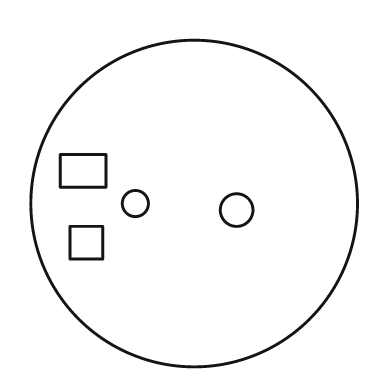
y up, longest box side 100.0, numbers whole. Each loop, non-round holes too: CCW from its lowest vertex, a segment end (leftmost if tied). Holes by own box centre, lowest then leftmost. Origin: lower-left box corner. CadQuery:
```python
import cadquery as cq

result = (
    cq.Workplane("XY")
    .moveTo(50.0, 50.0)
    .circle(50.0)
    .moveTo(12.0, 33.0)
    .lineTo(22.0, 33.0)
    .lineTo(22.0, 43.0)
    .lineTo(12.0, 43.0)
    .close()
    .moveTo(63.0, 48.0)
    .circle(5.0)
    .moveTo(32.0, 50.0)
    .circle(4.0)
    .moveTo(9.0, 55.0)
    .lineTo(23.0, 55.0)
    .lineTo(23.0, 65.0)
    .lineTo(9.0, 65.0)
    .close()
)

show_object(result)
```